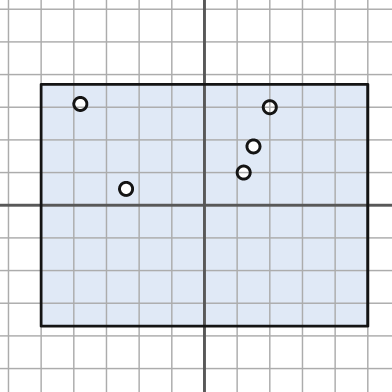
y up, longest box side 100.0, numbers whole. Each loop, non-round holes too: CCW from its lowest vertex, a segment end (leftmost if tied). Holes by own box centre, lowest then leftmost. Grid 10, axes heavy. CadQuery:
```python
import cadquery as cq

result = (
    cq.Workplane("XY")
    .moveTo(-50.0, -37.0)
    .lineTo(50.0, -37.0)
    .lineTo(50.0, 37.0)
    .lineTo(-50.0, 37.0)
    .close()
    .moveTo(-24.0, 5.0)
    .circle(2.0)
    .moveTo(12.0, 10.0)
    .circle(2.0)
    .moveTo(15.0, 18.0)
    .circle(2.0)
    .moveTo(20.0, 30.0)
    .circle(2.0)
    .moveTo(-38.0, 31.0)
    .circle(2.0)
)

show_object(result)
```